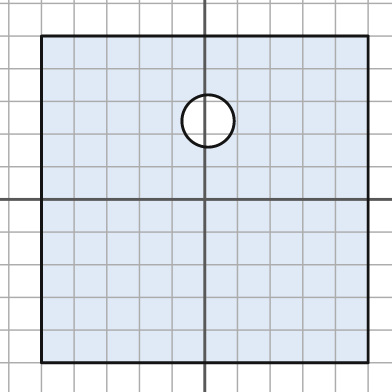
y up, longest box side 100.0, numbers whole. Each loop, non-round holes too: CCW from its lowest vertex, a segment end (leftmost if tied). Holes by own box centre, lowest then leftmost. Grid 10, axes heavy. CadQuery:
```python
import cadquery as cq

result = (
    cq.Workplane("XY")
    .moveTo(-50.0, -50.0)
    .lineTo(50.0, -50.0)
    .lineTo(50.0, 50.0)
    .lineTo(-50.0, 50.0)
    .close()
    .moveTo(1.0, 24.0)
    .circle(8.0)
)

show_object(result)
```